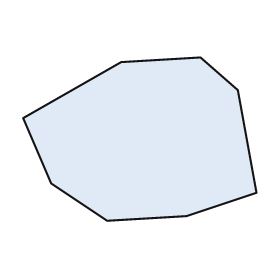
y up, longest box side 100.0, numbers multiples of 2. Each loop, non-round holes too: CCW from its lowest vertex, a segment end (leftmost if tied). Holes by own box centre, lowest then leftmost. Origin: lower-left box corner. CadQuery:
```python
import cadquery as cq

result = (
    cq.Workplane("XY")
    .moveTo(36.0, 0.0)
    .lineTo(70.0, 2.0)
    .lineTo(100.0, 12.0)
    .lineTo(92.0, 56.0)
    .lineTo(76.0, 70.0)
    .lineTo(42.0, 68.0)
    .lineTo(0.0, 44.0)
    .lineTo(12.0, 16.0)
    .close()
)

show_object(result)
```